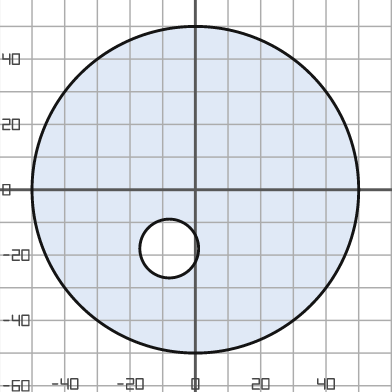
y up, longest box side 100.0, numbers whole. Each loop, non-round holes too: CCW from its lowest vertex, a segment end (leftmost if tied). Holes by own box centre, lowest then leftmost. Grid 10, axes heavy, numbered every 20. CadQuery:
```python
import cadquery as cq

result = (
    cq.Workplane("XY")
    .moveTo(0.0, 0.0)
    .circle(50.0)
    .moveTo(-8.0, -18.0)
    .circle(9.0)
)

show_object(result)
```